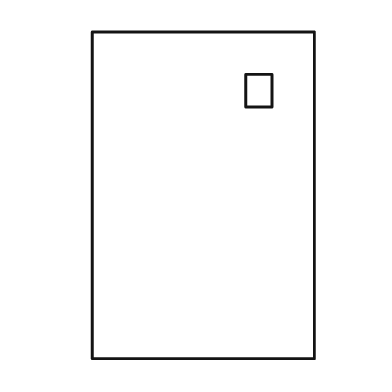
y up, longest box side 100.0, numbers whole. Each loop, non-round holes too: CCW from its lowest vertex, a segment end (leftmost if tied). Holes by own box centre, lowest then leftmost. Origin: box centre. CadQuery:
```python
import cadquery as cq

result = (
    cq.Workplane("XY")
    .moveTo(-34.0, -50.0)
    .lineTo(34.0, -50.0)
    .lineTo(34.0, 50.0)
    .lineTo(-34.0, 50.0)
    .close()
    .moveTo(13.0, 27.0)
    .lineTo(21.0, 27.0)
    .lineTo(21.0, 37.0)
    .lineTo(13.0, 37.0)
    .close()
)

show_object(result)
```